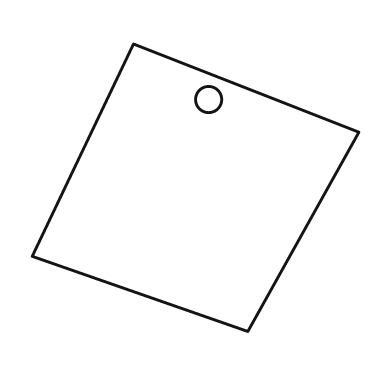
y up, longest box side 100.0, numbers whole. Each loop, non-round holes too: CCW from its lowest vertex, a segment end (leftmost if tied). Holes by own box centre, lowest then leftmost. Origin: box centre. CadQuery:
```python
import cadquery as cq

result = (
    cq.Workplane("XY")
    .moveTo(16.0, -44.0)
    .lineTo(50.0, 17.0)
    .lineTo(-19.0, 44.0)
    .lineTo(-50.0, -21.0)
    .close()
    .moveTo(4.0, 27.0)
    .circle(4.0)
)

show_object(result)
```